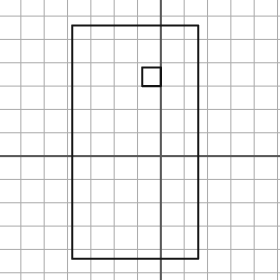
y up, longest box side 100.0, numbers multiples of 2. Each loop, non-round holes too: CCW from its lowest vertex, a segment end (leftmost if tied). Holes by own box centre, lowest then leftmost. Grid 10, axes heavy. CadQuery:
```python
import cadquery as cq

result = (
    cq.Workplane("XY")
    .moveTo(-38.0, -44.0)
    .lineTo(16.0, -44.0)
    .lineTo(16.0, 56.0)
    .lineTo(-38.0, 56.0)
    .close()
    .moveTo(-8.0, 30.0)
    .lineTo(0.0, 30.0)
    .lineTo(0.0, 38.0)
    .lineTo(-8.0, 38.0)
    .close()
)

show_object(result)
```